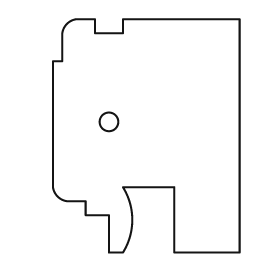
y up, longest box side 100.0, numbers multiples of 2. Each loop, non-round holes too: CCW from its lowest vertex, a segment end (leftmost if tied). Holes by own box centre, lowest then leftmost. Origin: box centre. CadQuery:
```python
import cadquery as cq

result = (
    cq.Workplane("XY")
    .moveTo(-16.0, -50.0)
    .lineTo(-10.0, -50.0)
    .threePointArc((-6.0, -36.0), (-10.0, -22.0))
    .lineTo(12.0, -22.0)
    .lineTo(12.0, -50.0)
    .lineTo(40.0, -50.0)
    .lineTo(40.0, 50.0)
    .lineTo(-10.0, 50.0)
    .lineTo(-10.0, 44.0)
    .lineTo(-22.0, 44.0)
    .lineTo(-22.0, 50.0)
    .lineTo(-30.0, 50.0)
    .threePointArc((-34.0, 48.0), (-36.0, 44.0))
    .lineTo(-36.0, 32.0)
    .lineTo(-40.0, 32.0)
    .lineTo(-40.0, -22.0)
    .threePointArc((-38.0, -26.0), (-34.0, -28.0))
    .lineTo(-26.0, -28.0)
    .lineTo(-26.0, -34.0)
    .lineTo(-16.0, -34.0)
    .close()
    .moveTo(-16.0, 6.0)
    .circle(4.0)
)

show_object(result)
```